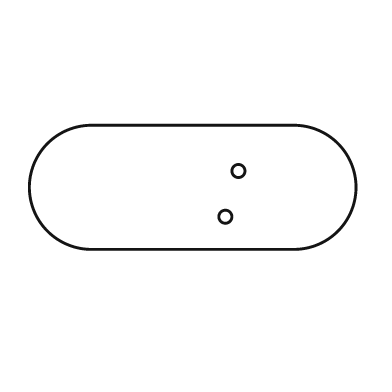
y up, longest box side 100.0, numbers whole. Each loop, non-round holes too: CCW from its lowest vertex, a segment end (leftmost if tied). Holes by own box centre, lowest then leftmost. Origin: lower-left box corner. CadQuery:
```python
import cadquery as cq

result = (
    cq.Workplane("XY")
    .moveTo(19.0, 0.0)
    .lineTo(81.0, 0.0)
    .threePointArc((100.0, 19.0), (81.0, 38.0))
    .lineTo(19.0, 38.0)
    .threePointArc((0.0, 19.0), (19.0, 0.0))
    .close()
    .moveTo(60.0, 10.0)
    .circle(2.0)
    .moveTo(64.0, 24.0)
    .circle(2.0)
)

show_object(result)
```